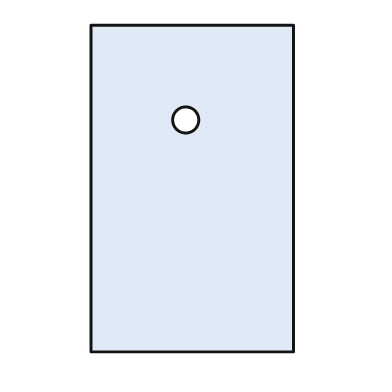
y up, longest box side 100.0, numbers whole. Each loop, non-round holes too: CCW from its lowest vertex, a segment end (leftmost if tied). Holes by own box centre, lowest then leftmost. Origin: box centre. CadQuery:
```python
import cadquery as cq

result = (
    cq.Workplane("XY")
    .moveTo(-31.0, -50.0)
    .lineTo(31.0, -50.0)
    .lineTo(31.0, 50.0)
    .lineTo(-31.0, 50.0)
    .close()
    .moveTo(-2.0, 21.0)
    .circle(4.0)
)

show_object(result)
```